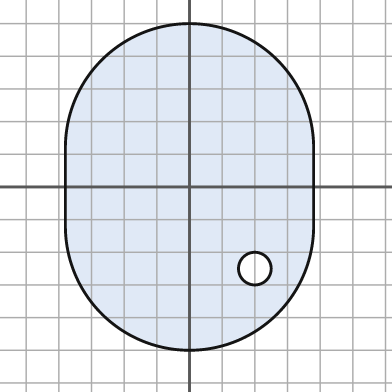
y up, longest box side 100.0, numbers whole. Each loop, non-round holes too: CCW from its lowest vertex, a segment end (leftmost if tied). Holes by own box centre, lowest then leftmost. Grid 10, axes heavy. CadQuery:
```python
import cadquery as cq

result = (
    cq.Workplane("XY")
    .moveTo(-38.0, -12.0)
    .threePointArc((0.0, -50.0), (38.0, -12.0))
    .lineTo(38.0, 12.0)
    .threePointArc((0.0, 50.0), (-38.0, 12.0))
    .close()
    .moveTo(20.0, -25.0)
    .circle(5.0)
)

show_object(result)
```